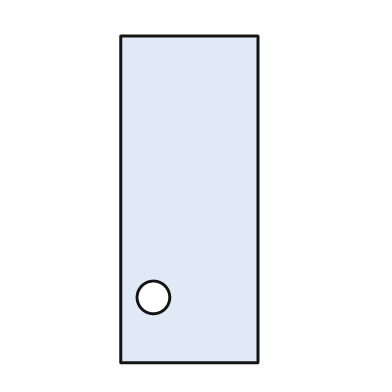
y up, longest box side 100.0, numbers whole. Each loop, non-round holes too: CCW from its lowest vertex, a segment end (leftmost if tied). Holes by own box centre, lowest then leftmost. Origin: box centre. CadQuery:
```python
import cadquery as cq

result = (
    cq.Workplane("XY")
    .moveTo(-21.0, -50.0)
    .lineTo(21.0, -50.0)
    .lineTo(21.0, 50.0)
    .lineTo(-21.0, 50.0)
    .close()
    .moveTo(-11.0, -30.0)
    .circle(5.0)
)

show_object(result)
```